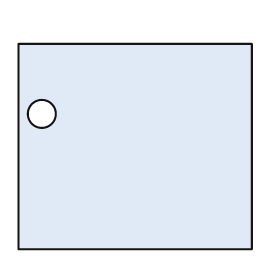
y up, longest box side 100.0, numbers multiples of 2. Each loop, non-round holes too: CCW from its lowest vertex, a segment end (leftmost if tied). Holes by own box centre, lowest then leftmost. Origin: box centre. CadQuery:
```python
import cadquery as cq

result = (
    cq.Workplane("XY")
    .moveTo(-50.0, -44.0)
    .lineTo(50.0, -44.0)
    .lineTo(50.0, 44.0)
    .lineTo(-50.0, 44.0)
    .close()
    .moveTo(-40.0, 14.0)
    .circle(6.0)
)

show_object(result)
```